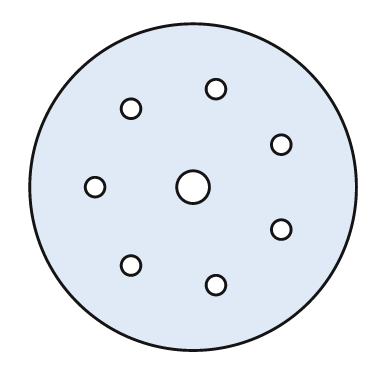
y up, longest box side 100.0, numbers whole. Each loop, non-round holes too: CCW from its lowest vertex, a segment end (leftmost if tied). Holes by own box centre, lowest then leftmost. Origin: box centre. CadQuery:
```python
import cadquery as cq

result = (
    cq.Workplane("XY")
    .moveTo(0.0, 0.0)
    .circle(50.0)
    .moveTo(7.0, -30.0)
    .circle(3.0)
    .moveTo(-19.0, -24.0)
    .circle(3.0)
    .moveTo(27.0, -13.0)
    .circle(3.0)
    .moveTo(-30.0, 0.0)
    .circle(3.0)
    .moveTo(0.0, 0.0)
    .circle(5.0)
    .moveTo(27.0, 13.0)
    .circle(3.0)
    .moveTo(-19.0, 24.0)
    .circle(3.0)
    .moveTo(7.0, 30.0)
    .circle(3.0)
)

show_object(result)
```